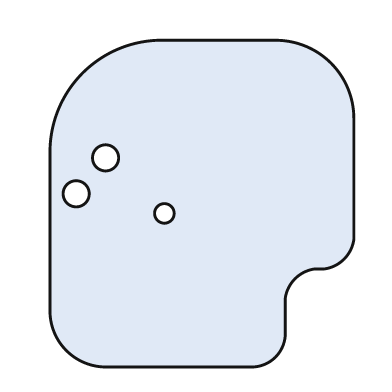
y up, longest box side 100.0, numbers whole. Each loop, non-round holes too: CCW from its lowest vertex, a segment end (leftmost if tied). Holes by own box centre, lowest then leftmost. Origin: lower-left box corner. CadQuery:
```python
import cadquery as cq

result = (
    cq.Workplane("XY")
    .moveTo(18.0, 0.0)
    .lineTo(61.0, 0.0)
    .threePointArc((69.0, 3.0), (72.0, 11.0))
    .lineTo(72.0, 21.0)
    .threePointArc((75.0, 27.0), (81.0, 30.0))
    .lineTo(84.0, 30.0)
    .threePointArc((90.0, 33.0), (93.0, 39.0))
    .lineTo(93.0, 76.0)
    .threePointArc((86.0, 93.0), (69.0, 100.0))
    .lineTo(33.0, 100.0)
    .threePointArc((10.0, 90.0), (0.0, 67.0))
    .lineTo(0.0, 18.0)
    .threePointArc((5.0, 5.0), (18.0, 0.0))
    .close()
    .moveTo(35.0, 47.0)
    .circle(3.0)
    .moveTo(8.0, 53.0)
    .circle(4.0)
    .moveTo(17.0, 64.0)
    .circle(4.0)
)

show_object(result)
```